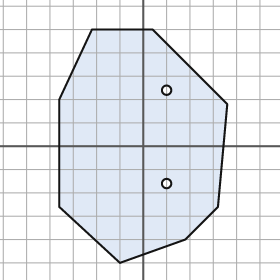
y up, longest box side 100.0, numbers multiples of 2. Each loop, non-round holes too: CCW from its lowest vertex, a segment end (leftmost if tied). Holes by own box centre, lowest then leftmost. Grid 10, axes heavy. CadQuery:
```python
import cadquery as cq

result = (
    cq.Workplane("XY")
    .moveTo(-10.0, -50.0)
    .lineTo(18.0, -40.0)
    .lineTo(32.0, -26.0)
    .lineTo(36.0, 18.0)
    .lineTo(4.0, 50.0)
    .lineTo(-22.0, 50.0)
    .lineTo(-36.0, 20.0)
    .lineTo(-36.0, -26.0)
    .close()
    .moveTo(10.0, -16.0)
    .circle(2.0)
    .moveTo(10.0, 24.0)
    .circle(2.0)
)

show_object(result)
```